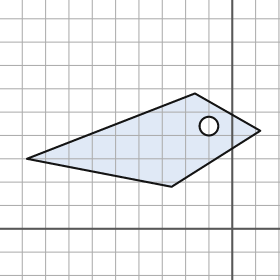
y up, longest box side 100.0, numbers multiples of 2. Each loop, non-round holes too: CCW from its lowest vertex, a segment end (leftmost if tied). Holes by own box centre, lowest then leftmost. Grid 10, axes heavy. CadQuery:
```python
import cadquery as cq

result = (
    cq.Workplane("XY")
    .moveTo(-26.0, 18.0)
    .lineTo(12.0, 42.0)
    .lineTo(-16.0, 58.0)
    .lineTo(-88.0, 30.0)
    .close()
    .moveTo(-10.0, 44.0)
    .circle(4.0)
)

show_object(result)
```